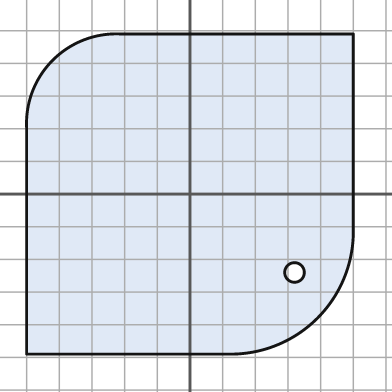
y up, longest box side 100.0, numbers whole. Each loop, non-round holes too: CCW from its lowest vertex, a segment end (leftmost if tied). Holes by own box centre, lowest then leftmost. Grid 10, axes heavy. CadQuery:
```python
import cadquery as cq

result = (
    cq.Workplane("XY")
    .moveTo(-50.0, -49.0)
    .lineTo(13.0, -49.0)
    .threePointArc((39.0, -38.0), (50.0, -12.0))
    .lineTo(50.0, 49.0)
    .lineTo(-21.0, 49.0)
    .threePointArc((-42.0, 41.0), (-50.0, 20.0))
    .close()
    .moveTo(32.0, -24.0)
    .circle(3.0)
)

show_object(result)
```